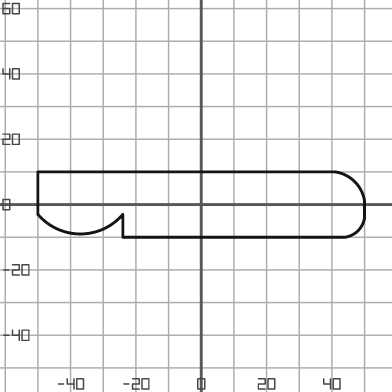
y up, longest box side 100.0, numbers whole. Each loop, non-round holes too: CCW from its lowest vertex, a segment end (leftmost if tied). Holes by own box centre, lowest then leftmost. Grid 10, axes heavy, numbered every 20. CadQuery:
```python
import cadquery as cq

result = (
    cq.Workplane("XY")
    .moveTo(-24.0, -10.0)
    .lineTo(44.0, -10.0)
    .threePointArc((48.0, -8.0), (50.0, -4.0))
    .lineTo(50.0, 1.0)
    .threePointArc((47.0, 7.0), (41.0, 10.0))
    .lineTo(-50.0, 10.0)
    .lineTo(-50.0, -3.0)
    .threePointArc((-37.0, -9.0), (-24.0, -3.0))
    .close()
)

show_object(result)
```